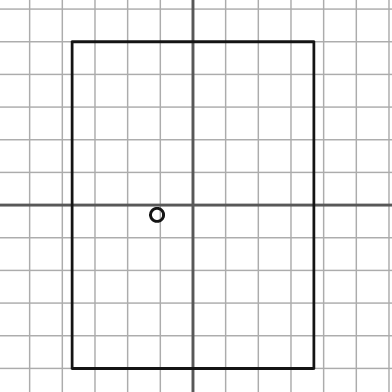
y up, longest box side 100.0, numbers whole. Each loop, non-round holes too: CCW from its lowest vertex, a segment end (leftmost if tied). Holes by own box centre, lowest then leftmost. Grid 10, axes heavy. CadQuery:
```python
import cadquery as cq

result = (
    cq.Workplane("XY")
    .moveTo(-37.0, -50.0)
    .lineTo(37.0, -50.0)
    .lineTo(37.0, 50.0)
    .lineTo(-37.0, 50.0)
    .close()
    .moveTo(-11.0, -3.0)
    .circle(2.0)
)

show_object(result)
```